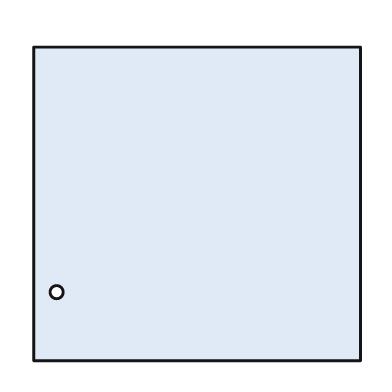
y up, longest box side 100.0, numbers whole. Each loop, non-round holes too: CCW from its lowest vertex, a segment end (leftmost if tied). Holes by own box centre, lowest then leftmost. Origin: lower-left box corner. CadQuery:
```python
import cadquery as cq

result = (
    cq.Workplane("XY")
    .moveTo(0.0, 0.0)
    .lineTo(100.0, 0.0)
    .lineTo(100.0, 96.0)
    .lineTo(0.0, 96.0)
    .close()
    .moveTo(7.0, 21.0)
    .circle(2.0)
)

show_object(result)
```